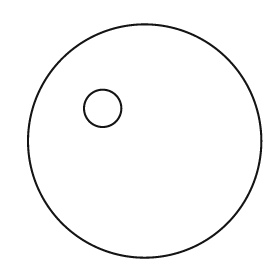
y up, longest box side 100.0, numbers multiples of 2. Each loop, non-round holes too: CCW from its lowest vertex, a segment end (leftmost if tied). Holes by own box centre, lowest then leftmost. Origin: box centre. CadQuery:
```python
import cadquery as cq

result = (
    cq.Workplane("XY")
    .moveTo(0.0, 0.0)
    .circle(50.0)
    .moveTo(-18.0, 14.0)
    .circle(8.0)
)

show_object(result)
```